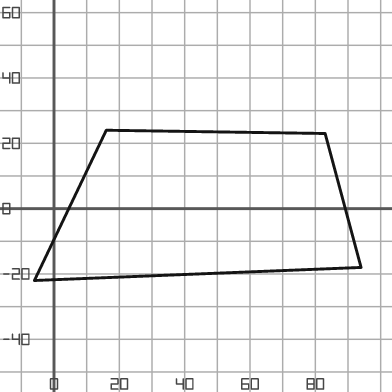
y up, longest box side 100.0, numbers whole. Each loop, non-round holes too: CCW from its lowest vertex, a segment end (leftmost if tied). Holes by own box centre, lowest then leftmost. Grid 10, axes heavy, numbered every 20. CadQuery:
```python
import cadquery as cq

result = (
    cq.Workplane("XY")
    .moveTo(-6.0, -22.0)
    .lineTo(94.0, -18.0)
    .lineTo(83.0, 23.0)
    .lineTo(16.0, 24.0)
    .close()
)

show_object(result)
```